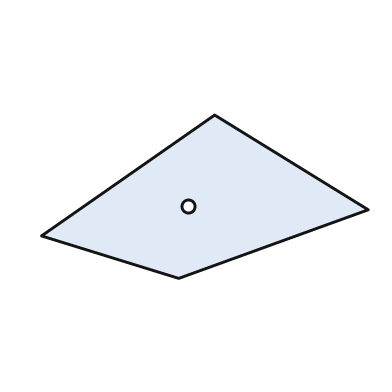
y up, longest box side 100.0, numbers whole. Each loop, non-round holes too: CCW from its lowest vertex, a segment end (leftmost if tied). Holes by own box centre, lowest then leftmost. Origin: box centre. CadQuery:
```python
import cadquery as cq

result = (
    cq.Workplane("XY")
    .moveTo(-8.0, -25.0)
    .lineTo(50.0, -4.0)
    .lineTo(3.0, 25.0)
    .lineTo(-50.0, -12.0)
    .close()
    .moveTo(-5.0, -3.0)
    .circle(2.0)
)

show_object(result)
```